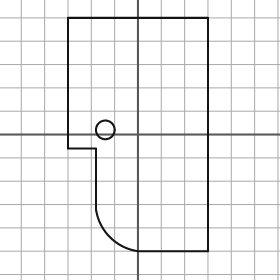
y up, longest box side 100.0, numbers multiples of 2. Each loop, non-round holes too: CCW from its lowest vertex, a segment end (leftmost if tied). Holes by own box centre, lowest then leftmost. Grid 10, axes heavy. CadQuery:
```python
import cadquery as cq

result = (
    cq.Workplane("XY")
    .moveTo(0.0, -50.0)
    .lineTo(30.0, -50.0)
    .lineTo(30.0, 50.0)
    .lineTo(-30.0, 50.0)
    .lineTo(-30.0, -6.0)
    .lineTo(-18.0, -6.0)
    .lineTo(-18.0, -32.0)
    .threePointArc((-12.0, -44.0), (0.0, -50.0))
    .close()
    .moveTo(-14.0, 2.0)
    .circle(4.0)
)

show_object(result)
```